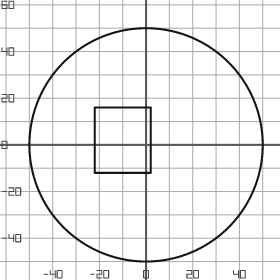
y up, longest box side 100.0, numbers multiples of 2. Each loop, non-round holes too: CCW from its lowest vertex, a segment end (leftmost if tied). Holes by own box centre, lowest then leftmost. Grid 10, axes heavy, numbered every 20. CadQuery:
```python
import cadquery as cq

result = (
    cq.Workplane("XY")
    .moveTo(0.0, 0.0)
    .circle(50.0)
    .moveTo(-22.0, -12.0)
    .lineTo(2.0, -12.0)
    .lineTo(2.0, 16.0)
    .lineTo(-22.0, 16.0)
    .close()
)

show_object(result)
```